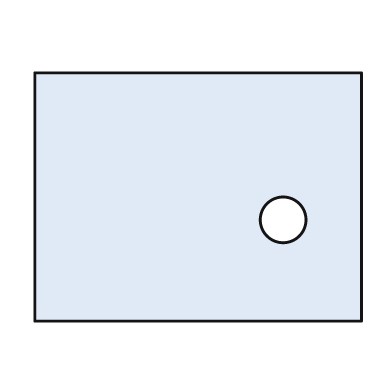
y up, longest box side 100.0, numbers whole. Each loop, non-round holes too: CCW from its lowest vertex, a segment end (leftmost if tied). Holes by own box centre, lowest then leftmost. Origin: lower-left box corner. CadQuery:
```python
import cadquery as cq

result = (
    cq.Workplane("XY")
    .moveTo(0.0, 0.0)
    .lineTo(100.0, 0.0)
    .lineTo(100.0, 76.0)
    .lineTo(0.0, 76.0)
    .close()
    .moveTo(76.0, 31.0)
    .circle(7.0)
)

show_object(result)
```